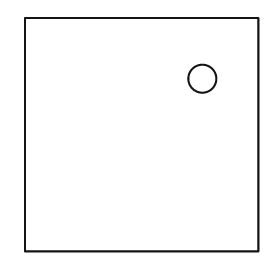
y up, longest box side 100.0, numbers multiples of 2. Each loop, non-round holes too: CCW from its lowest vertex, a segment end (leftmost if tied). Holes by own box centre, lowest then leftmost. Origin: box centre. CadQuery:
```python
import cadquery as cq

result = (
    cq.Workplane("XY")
    .moveTo(-50.0, -50.0)
    .lineTo(50.0, -50.0)
    .lineTo(50.0, 50.0)
    .lineTo(-50.0, 50.0)
    .close()
    .moveTo(26.0, 24.0)
    .circle(6.0)
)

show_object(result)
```